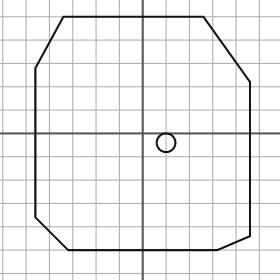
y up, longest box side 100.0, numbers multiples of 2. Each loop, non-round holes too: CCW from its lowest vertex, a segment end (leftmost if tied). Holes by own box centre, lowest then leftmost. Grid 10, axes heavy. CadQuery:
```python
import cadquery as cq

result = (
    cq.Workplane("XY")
    .moveTo(-32.0, -50.0)
    .lineTo(32.0, -50.0)
    .lineTo(46.0, -44.0)
    .lineTo(46.0, 22.0)
    .lineTo(26.0, 50.0)
    .lineTo(-34.0, 50.0)
    .lineTo(-46.0, 28.0)
    .lineTo(-46.0, -36.0)
    .close()
    .moveTo(10.0, -4.0)
    .circle(4.0)
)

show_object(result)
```